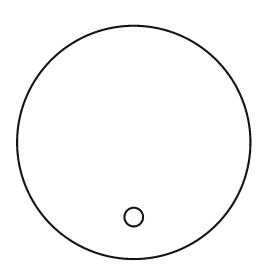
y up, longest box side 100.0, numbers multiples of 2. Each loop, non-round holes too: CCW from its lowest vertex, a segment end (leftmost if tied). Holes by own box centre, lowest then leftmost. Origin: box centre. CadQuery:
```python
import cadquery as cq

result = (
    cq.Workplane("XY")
    .moveTo(0.0, 0.0)
    .circle(50.0)
    .moveTo(0.0, -32.0)
    .circle(4.0)
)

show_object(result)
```